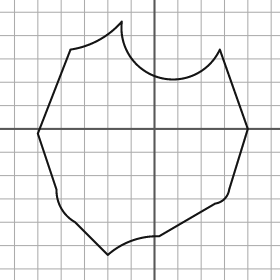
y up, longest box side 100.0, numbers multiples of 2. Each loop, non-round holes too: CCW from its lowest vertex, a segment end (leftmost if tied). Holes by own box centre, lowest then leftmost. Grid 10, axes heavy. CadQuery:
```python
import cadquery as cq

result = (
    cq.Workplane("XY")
    .moveTo(-20.0, -54.0)
    .threePointArc((-10.0, -48.0), (2.0, -46.0))
    .lineTo(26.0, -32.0)
    .threePointArc((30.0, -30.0), (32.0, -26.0))
    .lineTo(40.0, 0.0)
    .lineTo(28.0, 34.0)
    .threePointArc((2.0, 22.0), (-14.0, 46.0))
    .threePointArc((-24.0, 38.0), (-36.0, 34.0))
    .lineTo(-50.0, -2.0)
    .lineTo(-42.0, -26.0)
    .threePointArc((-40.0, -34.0), (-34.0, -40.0))
    .close()
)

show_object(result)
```